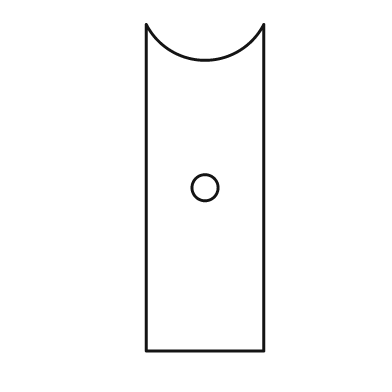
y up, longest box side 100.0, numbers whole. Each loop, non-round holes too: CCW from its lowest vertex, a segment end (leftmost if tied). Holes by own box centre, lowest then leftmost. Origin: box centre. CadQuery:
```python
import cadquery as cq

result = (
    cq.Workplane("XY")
    .moveTo(-18.0, -50.0)
    .lineTo(18.0, -50.0)
    .lineTo(18.0, 50.0)
    .threePointArc((0.0, 39.0), (-18.0, 50.0))
    .close()
    .moveTo(0.0, 0.0)
    .circle(4.0)
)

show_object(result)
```